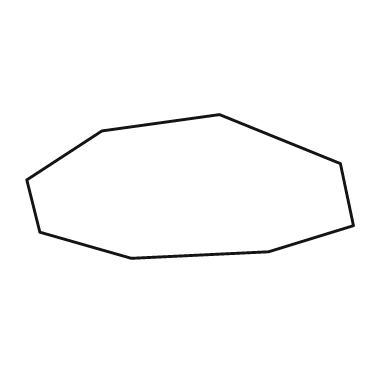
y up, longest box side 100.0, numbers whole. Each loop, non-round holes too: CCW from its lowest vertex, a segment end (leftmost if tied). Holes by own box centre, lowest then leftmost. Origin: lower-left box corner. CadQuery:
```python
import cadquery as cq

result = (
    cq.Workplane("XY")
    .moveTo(32.0, 0.0)
    .lineTo(74.0, 2.0)
    .lineTo(100.0, 10.0)
    .lineTo(96.0, 29.0)
    .lineTo(59.0, 44.0)
    .lineTo(23.0, 39.0)
    .lineTo(0.0, 24.0)
    .lineTo(4.0, 8.0)
    .close()
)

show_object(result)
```